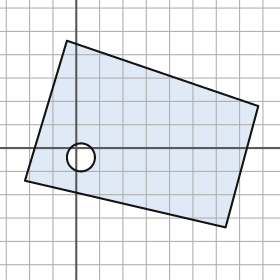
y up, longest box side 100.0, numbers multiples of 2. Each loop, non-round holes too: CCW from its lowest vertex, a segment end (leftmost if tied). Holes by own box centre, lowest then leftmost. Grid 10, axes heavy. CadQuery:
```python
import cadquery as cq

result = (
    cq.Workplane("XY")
    .moveTo(64.0, -34.0)
    .lineTo(78.0, 18.0)
    .lineTo(-4.0, 46.0)
    .lineTo(-22.0, -14.0)
    .close()
    .moveTo(2.0, -4.0)
    .circle(6.0)
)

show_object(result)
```